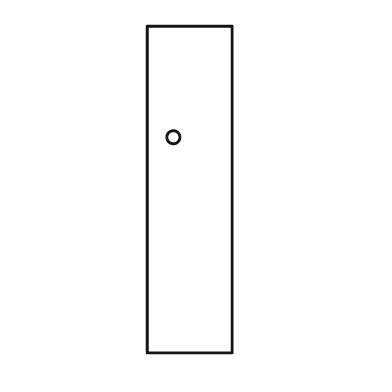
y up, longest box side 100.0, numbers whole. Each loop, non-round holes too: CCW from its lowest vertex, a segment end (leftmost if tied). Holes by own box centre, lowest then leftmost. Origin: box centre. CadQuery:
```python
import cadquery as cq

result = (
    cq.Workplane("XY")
    .moveTo(-13.0, -50.0)
    .lineTo(13.0, -50.0)
    .lineTo(13.0, 50.0)
    .lineTo(-13.0, 50.0)
    .close()
    .moveTo(-5.0, 16.0)
    .circle(2.0)
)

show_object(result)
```